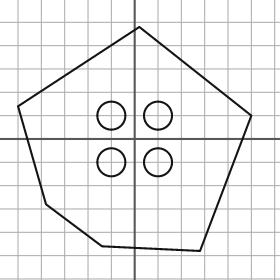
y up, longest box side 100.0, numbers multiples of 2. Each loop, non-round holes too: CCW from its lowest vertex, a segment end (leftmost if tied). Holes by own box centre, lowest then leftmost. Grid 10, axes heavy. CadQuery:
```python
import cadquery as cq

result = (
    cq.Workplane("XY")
    .moveTo(28.0, -48.0)
    .lineTo(50.0, 10.0)
    .lineTo(2.0, 48.0)
    .lineTo(-50.0, 14.0)
    .lineTo(-38.0, -28.0)
    .lineTo(-14.0, -46.0)
    .close()
    .moveTo(-10.0, -10.0)
    .circle(6.0)
    .moveTo(10.0, -10.0)
    .circle(6.0)
    .moveTo(-10.0, 10.0)
    .circle(6.0)
    .moveTo(10.0, 10.0)
    .circle(6.0)
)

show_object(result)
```